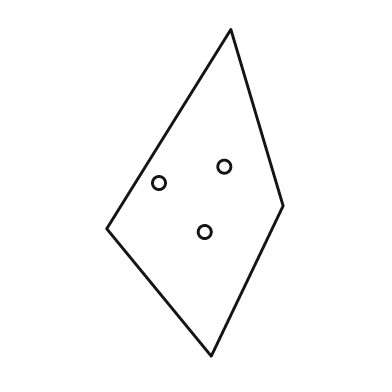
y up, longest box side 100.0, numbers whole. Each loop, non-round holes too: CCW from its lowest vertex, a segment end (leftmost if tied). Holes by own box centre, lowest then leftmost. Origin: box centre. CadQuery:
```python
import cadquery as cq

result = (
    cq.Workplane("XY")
    .moveTo(5.0, -50.0)
    .lineTo(27.0, -4.0)
    .lineTo(11.0, 50.0)
    .lineTo(-27.0, -11.0)
    .close()
    .moveTo(3.0, -12.0)
    .circle(2.0)
    .moveTo(-11.0, 3.0)
    .circle(2.0)
    .moveTo(9.0, 8.0)
    .circle(2.0)
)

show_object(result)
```